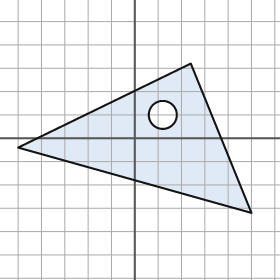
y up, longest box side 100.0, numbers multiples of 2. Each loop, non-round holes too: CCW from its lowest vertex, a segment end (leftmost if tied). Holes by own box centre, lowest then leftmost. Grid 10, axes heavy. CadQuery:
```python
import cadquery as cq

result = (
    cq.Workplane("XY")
    .moveTo(50.0, -32.0)
    .lineTo(24.0, 32.0)
    .lineTo(-50.0, -4.0)
    .close()
    .moveTo(12.0, 10.0)
    .circle(6.0)
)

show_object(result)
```